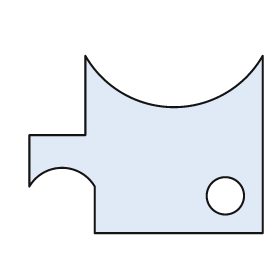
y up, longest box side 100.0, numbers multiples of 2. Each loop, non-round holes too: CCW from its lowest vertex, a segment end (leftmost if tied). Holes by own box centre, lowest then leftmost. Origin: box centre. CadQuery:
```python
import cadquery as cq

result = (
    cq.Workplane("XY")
    .moveTo(-22.0, -38.0)
    .lineTo(50.0, -38.0)
    .lineTo(50.0, 38.0)
    .threePointArc((12.0, 16.0), (-26.0, 38.0))
    .lineTo(-26.0, 4.0)
    .lineTo(-50.0, 4.0)
    .lineTo(-50.0, -18.0)
    .threePointArc((-36.0, -10.0), (-22.0, -18.0))
    .close()
    .moveTo(34.0, -22.0)
    .circle(8.0)
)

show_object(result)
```